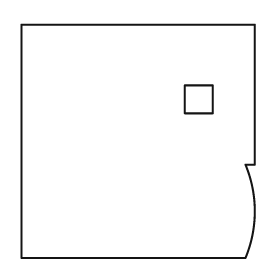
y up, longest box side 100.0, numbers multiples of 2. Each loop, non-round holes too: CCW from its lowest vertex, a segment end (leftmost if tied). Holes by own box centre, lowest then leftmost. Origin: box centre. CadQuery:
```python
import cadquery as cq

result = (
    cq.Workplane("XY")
    .moveTo(-50.0, -50.0)
    .lineTo(46.0, -50.0)
    .threePointArc((50.0, -30.0), (46.0, -10.0))
    .lineTo(50.0, -10.0)
    .lineTo(50.0, 50.0)
    .lineTo(-50.0, 50.0)
    .close()
    .moveTo(20.0, 12.0)
    .lineTo(32.0, 12.0)
    .lineTo(32.0, 24.0)
    .lineTo(20.0, 24.0)
    .close()
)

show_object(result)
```